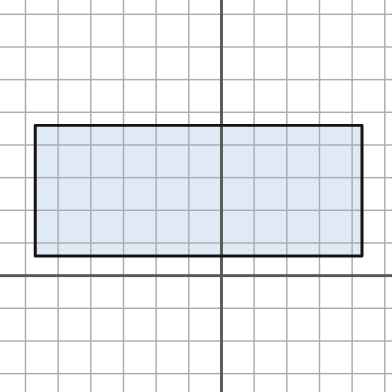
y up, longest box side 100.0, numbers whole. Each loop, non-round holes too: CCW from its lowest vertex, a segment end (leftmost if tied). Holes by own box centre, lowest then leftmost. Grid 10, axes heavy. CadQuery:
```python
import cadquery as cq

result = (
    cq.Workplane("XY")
    .moveTo(-57.0, 6.0)
    .lineTo(43.0, 6.0)
    .lineTo(43.0, 46.0)
    .lineTo(-57.0, 46.0)
    .close()
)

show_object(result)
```